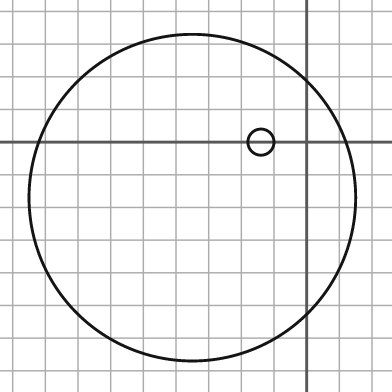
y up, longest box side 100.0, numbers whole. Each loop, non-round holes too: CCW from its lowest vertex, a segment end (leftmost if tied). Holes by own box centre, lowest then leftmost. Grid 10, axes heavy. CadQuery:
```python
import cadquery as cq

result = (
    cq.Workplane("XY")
    .moveTo(-35.0, -17.0)
    .circle(50.0)
    .moveTo(-14.0, 0.0)
    .circle(4.0)
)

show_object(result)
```